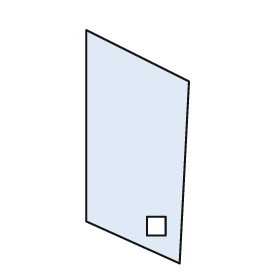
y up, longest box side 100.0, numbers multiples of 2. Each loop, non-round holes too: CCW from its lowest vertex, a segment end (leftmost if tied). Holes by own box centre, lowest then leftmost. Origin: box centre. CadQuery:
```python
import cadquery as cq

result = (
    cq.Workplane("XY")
    .moveTo(18.0, -50.0)
    .lineTo(22.0, 28.0)
    .lineTo(-22.0, 50.0)
    .lineTo(-22.0, -32.0)
    .close()
    .moveTo(4.0, -38.0)
    .lineTo(12.0, -38.0)
    .lineTo(12.0, -30.0)
    .lineTo(4.0, -30.0)
    .close()
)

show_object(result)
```